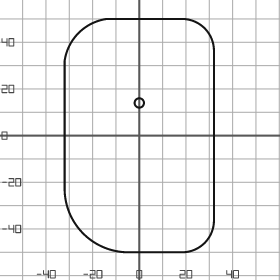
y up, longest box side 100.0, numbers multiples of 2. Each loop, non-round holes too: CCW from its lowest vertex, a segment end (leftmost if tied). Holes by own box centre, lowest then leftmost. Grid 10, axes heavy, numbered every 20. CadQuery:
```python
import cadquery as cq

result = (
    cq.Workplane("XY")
    .moveTo(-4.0, -50.0)
    .lineTo(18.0, -50.0)
    .threePointArc((28.0, -46.0), (32.0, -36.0))
    .lineTo(32.0, 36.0)
    .threePointArc((28.0, 46.0), (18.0, 50.0))
    .lineTo(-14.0, 50.0)
    .threePointArc((-26.0, 44.0), (-32.0, 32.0))
    .lineTo(-32.0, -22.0)
    .threePointArc((-24.0, -42.0), (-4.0, -50.0))
    .close()
    .moveTo(0.0, 14.0)
    .circle(2.0)
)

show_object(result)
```